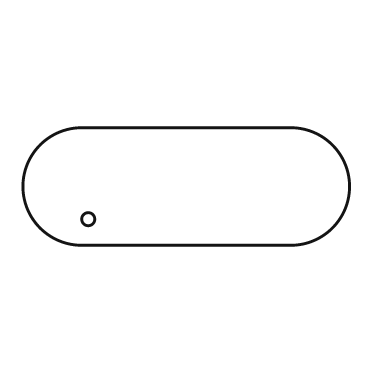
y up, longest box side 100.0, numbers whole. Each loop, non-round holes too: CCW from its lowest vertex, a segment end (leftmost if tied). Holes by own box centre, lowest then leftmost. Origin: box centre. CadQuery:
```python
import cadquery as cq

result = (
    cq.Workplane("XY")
    .moveTo(-32.0, -18.0)
    .lineTo(32.0, -18.0)
    .threePointArc((50.0, 0.0), (32.0, 18.0))
    .lineTo(-32.0, 18.0)
    .threePointArc((-50.0, 0.0), (-32.0, -18.0))
    .close()
    .moveTo(-30.0, -10.0)
    .circle(2.0)
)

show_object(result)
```